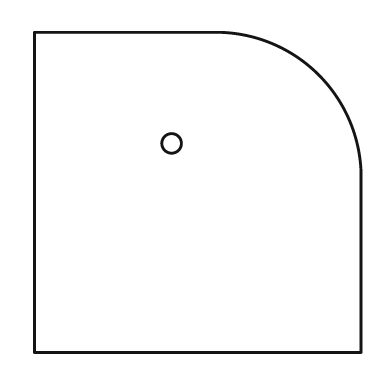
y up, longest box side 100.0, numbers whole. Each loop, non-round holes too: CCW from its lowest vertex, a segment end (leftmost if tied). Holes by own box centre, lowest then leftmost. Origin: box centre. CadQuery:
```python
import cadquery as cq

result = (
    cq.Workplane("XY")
    .moveTo(-50.0, -49.0)
    .lineTo(50.0, -49.0)
    .lineTo(50.0, 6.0)
    .threePointArc((37.0, 36.0), (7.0, 49.0))
    .lineTo(-50.0, 49.0)
    .close()
    .moveTo(-8.0, 15.0)
    .circle(3.0)
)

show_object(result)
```